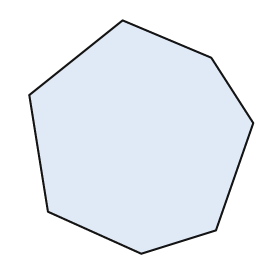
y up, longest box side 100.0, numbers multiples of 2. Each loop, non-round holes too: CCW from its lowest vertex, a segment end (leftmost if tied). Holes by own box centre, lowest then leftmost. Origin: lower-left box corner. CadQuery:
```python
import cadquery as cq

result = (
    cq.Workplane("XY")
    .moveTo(48.0, 0.0)
    .lineTo(80.0, 10.0)
    .lineTo(96.0, 56.0)
    .lineTo(78.0, 84.0)
    .lineTo(40.0, 100.0)
    .lineTo(0.0, 68.0)
    .lineTo(8.0, 18.0)
    .close()
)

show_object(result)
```